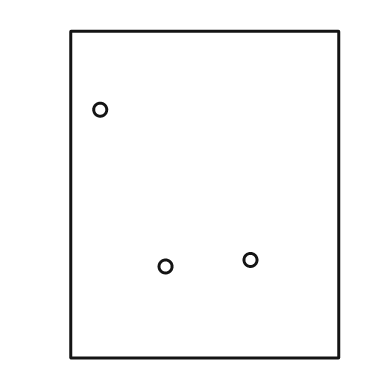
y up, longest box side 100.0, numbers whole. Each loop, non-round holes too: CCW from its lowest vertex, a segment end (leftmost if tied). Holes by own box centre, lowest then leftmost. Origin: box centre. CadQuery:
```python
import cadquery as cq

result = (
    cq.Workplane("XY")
    .moveTo(-41.0, -50.0)
    .lineTo(41.0, -50.0)
    .lineTo(41.0, 50.0)
    .lineTo(-41.0, 50.0)
    .close()
    .moveTo(-12.0, -22.0)
    .circle(2.0)
    .moveTo(14.0, -20.0)
    .circle(2.0)
    .moveTo(-32.0, 26.0)
    .circle(2.0)
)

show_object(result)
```